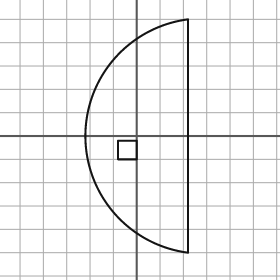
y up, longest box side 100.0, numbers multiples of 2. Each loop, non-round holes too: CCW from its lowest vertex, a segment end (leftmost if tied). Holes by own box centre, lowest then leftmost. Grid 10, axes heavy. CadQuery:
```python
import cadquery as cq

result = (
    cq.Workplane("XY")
    .moveTo(22.0, -50.0)
    .lineTo(22.0, 50.0)
    .threePointArc((-22.0, 0.0), (22.0, -50.0))
    .close()
    .moveTo(-8.0, -10.0)
    .lineTo(0.0, -10.0)
    .lineTo(0.0, -2.0)
    .lineTo(-8.0, -2.0)
    .close()
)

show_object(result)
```